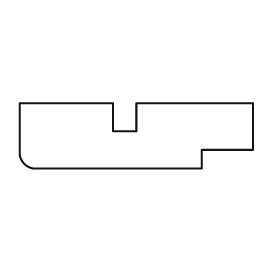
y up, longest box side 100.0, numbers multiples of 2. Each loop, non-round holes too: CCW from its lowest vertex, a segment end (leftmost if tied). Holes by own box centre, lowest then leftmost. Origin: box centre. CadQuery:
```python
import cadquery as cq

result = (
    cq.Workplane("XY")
    .moveTo(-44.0, -14.0)
    .lineTo(28.0, -14.0)
    .lineTo(28.0, -6.0)
    .lineTo(50.0, -6.0)
    .lineTo(50.0, 14.0)
    .lineTo(0.0, 14.0)
    .lineTo(0.0, 2.0)
    .lineTo(-10.0, 2.0)
    .lineTo(-10.0, 14.0)
    .lineTo(-50.0, 14.0)
    .lineTo(-50.0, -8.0)
    .threePointArc((-48.0, -12.0), (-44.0, -14.0))
    .close()
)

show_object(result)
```